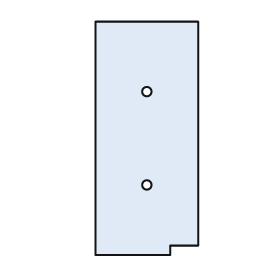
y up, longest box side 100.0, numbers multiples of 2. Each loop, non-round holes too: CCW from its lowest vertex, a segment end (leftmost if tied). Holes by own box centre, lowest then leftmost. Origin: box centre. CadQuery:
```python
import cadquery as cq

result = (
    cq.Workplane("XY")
    .moveTo(-22.0, -50.0)
    .lineTo(10.0, -50.0)
    .lineTo(10.0, -46.0)
    .lineTo(22.0, -46.0)
    .lineTo(22.0, 50.0)
    .lineTo(-22.0, 50.0)
    .close()
    .moveTo(0.0, -20.0)
    .circle(2.0)
    .moveTo(0.0, 20.0)
    .circle(2.0)
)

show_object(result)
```